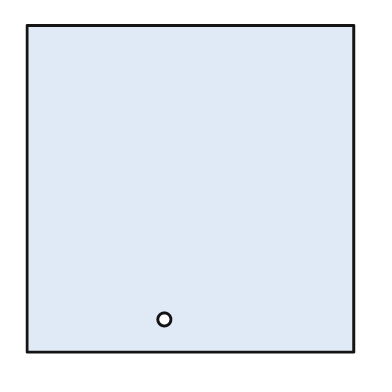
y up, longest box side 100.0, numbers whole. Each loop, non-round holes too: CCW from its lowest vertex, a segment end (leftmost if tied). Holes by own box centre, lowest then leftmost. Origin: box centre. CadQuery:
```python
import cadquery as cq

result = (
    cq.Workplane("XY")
    .moveTo(-50.0, -50.0)
    .lineTo(50.0, -50.0)
    .lineTo(50.0, 50.0)
    .lineTo(-50.0, 50.0)
    .close()
    .moveTo(-8.0, -40.0)
    .circle(2.0)
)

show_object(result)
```